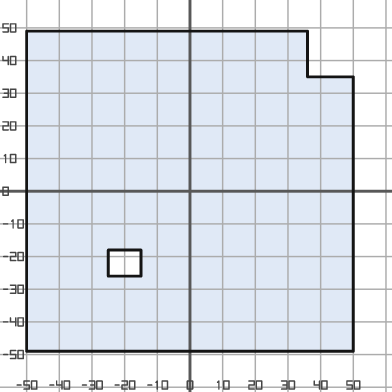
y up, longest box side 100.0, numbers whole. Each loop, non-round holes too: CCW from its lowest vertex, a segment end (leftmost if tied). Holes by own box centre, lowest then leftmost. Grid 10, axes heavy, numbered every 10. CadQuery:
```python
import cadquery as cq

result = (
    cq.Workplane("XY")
    .moveTo(-50.0, -49.0)
    .lineTo(50.0, -49.0)
    .lineTo(50.0, 35.0)
    .lineTo(36.0, 35.0)
    .lineTo(36.0, 49.0)
    .lineTo(-50.0, 49.0)
    .close()
    .moveTo(-25.0, -26.0)
    .lineTo(-15.0, -26.0)
    .lineTo(-15.0, -18.0)
    .lineTo(-25.0, -18.0)
    .close()
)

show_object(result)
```